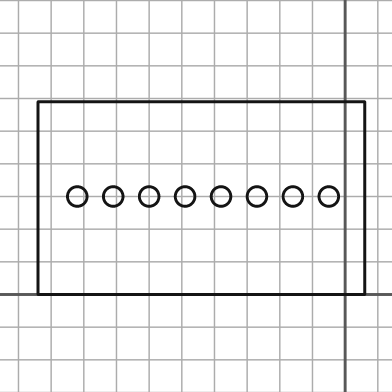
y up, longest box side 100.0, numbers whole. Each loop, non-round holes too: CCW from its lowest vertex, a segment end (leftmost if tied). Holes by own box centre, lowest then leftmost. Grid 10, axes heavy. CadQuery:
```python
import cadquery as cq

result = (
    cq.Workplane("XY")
    .moveTo(-94.0, 0.0)
    .lineTo(6.0, 0.0)
    .lineTo(6.0, 59.0)
    .lineTo(-94.0, 59.0)
    .close()
    .moveTo(-82.0, 30.0)
    .circle(3.0)
    .moveTo(-71.0, 30.0)
    .circle(3.0)
    .moveTo(-60.0, 30.0)
    .circle(3.0)
    .moveTo(-49.0, 30.0)
    .circle(3.0)
    .moveTo(-38.0, 30.0)
    .circle(3.0)
    .moveTo(-27.0, 30.0)
    .circle(3.0)
    .moveTo(-16.0, 30.0)
    .circle(3.0)
    .moveTo(-5.0, 30.0)
    .circle(3.0)
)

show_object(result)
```